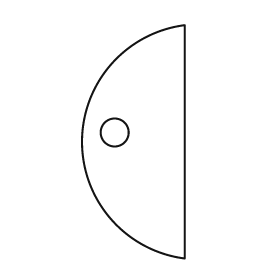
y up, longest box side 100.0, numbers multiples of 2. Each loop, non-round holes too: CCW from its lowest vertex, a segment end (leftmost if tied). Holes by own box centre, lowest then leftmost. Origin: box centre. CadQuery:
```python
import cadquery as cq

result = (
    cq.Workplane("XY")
    .moveTo(22.0, -50.0)
    .lineTo(22.0, 50.0)
    .threePointArc((-22.0, 0.0), (22.0, -50.0))
    .close()
    .moveTo(-8.0, 4.0)
    .circle(6.0)
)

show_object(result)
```